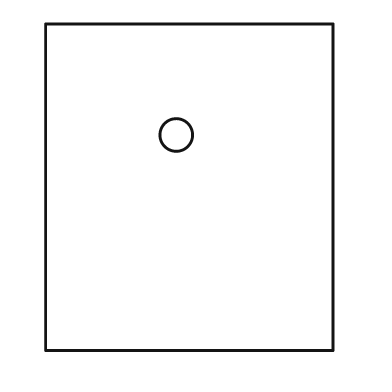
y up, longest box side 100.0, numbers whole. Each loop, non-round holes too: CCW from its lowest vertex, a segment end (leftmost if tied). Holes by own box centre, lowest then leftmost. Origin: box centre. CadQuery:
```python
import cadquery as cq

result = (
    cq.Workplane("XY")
    .moveTo(-44.0, -50.0)
    .lineTo(44.0, -50.0)
    .lineTo(44.0, 50.0)
    .lineTo(-44.0, 50.0)
    .close()
    .moveTo(-4.0, 16.0)
    .circle(5.0)
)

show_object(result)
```